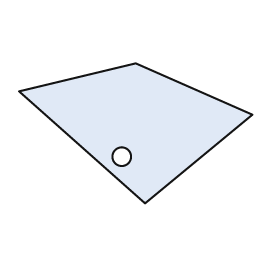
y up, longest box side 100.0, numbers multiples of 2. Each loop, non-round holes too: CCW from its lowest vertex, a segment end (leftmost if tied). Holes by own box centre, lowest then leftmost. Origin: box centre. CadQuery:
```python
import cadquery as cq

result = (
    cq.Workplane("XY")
    .moveTo(4.0, -30.0)
    .lineTo(50.0, 8.0)
    .lineTo(0.0, 30.0)
    .lineTo(-50.0, 18.0)
    .close()
    .moveTo(-6.0, -10.0)
    .circle(4.0)
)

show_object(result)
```